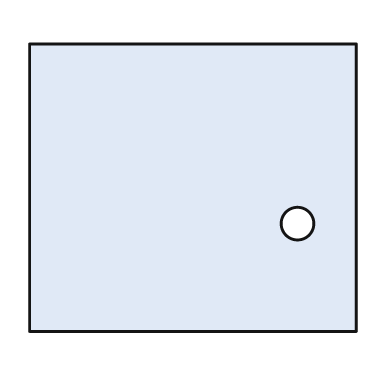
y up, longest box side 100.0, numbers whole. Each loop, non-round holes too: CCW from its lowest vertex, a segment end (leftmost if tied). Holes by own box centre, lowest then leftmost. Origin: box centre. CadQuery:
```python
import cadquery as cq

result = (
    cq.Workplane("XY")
    .moveTo(-50.0, -44.0)
    .lineTo(50.0, -44.0)
    .lineTo(50.0, 44.0)
    .lineTo(-50.0, 44.0)
    .close()
    .moveTo(32.0, -11.0)
    .circle(5.0)
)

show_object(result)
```